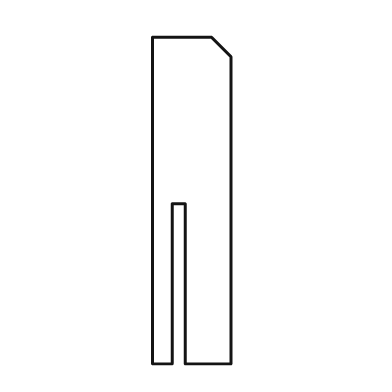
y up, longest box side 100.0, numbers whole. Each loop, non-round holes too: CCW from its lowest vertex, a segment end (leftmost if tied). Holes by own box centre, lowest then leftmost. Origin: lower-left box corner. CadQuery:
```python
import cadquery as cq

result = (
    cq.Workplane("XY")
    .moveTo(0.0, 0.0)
    .lineTo(6.0, 0.0)
    .lineTo(6.0, 49.0)
    .lineTo(10.0, 49.0)
    .lineTo(10.0, 0.0)
    .lineTo(24.0, 0.0)
    .lineTo(24.0, 94.0)
    .lineTo(18.0, 100.0)
    .lineTo(0.0, 100.0)
    .close()
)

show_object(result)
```